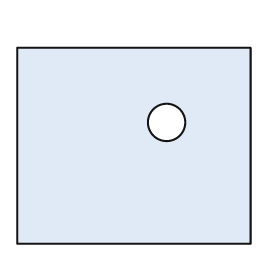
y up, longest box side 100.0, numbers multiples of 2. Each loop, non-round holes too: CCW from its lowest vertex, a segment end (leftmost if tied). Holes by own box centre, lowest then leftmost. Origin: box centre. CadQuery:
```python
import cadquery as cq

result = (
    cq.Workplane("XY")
    .moveTo(-50.0, -42.0)
    .lineTo(50.0, -42.0)
    .lineTo(50.0, 42.0)
    .lineTo(-50.0, 42.0)
    .close()
    .moveTo(14.0, 10.0)
    .circle(8.0)
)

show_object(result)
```